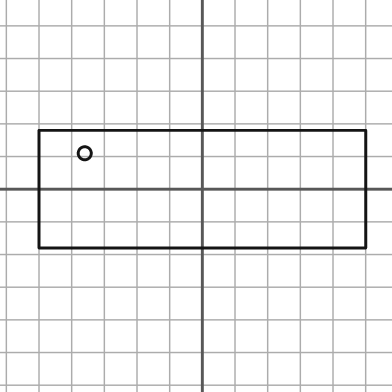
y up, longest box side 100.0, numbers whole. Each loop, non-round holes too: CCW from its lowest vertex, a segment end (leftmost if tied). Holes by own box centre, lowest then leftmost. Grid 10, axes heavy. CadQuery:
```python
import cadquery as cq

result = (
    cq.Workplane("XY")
    .moveTo(-50.0, -18.0)
    .lineTo(50.0, -18.0)
    .lineTo(50.0, 18.0)
    .lineTo(-50.0, 18.0)
    .close()
    .moveTo(-36.0, 11.0)
    .circle(2.0)
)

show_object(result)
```